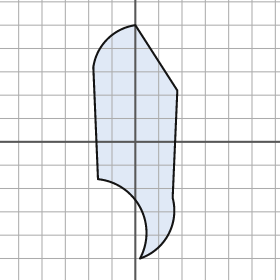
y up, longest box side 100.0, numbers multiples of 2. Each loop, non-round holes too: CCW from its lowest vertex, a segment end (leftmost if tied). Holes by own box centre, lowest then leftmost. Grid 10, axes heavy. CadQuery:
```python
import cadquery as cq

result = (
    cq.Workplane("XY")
    .moveTo(2.0, -50.0)
    .threePointArc((14.0, -40.0), (16.0, -24.0))
    .lineTo(18.0, 22.0)
    .lineTo(0.0, 50.0)
    .threePointArc((-12.0, 44.0), (-18.0, 32.0))
    .lineTo(-16.0, -16.0)
    .threePointArc((2.0, -28.0), (2.0, -50.0))
    .close()
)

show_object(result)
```